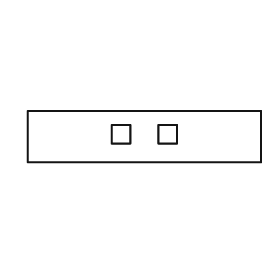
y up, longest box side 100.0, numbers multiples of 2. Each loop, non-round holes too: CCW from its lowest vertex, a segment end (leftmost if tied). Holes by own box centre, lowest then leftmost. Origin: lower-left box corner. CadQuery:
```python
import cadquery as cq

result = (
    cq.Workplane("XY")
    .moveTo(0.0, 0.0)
    .lineTo(100.0, 0.0)
    .lineTo(100.0, 22.0)
    .lineTo(0.0, 22.0)
    .close()
    .moveTo(36.0, 8.0)
    .lineTo(44.0, 8.0)
    .lineTo(44.0, 16.0)
    .lineTo(36.0, 16.0)
    .close()
    .moveTo(56.0, 8.0)
    .lineTo(64.0, 8.0)
    .lineTo(64.0, 16.0)
    .lineTo(56.0, 16.0)
    .close()
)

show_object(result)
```